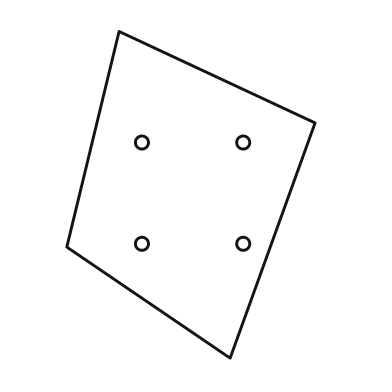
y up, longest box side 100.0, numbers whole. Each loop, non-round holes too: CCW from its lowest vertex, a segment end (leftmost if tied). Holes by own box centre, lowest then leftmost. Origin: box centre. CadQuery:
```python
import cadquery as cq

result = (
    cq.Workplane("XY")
    .moveTo(12.0, -50.0)
    .lineTo(38.0, 22.0)
    .lineTo(-22.0, 50.0)
    .lineTo(-38.0, -16.0)
    .close()
    .moveTo(-15.0, -15.0)
    .circle(2.0)
    .moveTo(16.0, -15.0)
    .circle(2.0)
    .moveTo(-15.0, 16.0)
    .circle(2.0)
    .moveTo(16.0, 16.0)
    .circle(2.0)
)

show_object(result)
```